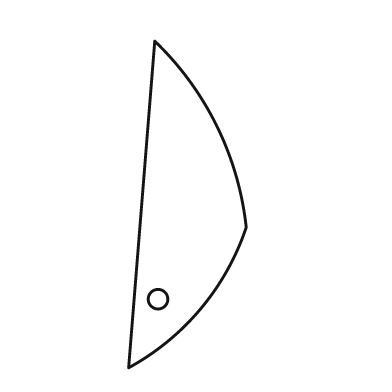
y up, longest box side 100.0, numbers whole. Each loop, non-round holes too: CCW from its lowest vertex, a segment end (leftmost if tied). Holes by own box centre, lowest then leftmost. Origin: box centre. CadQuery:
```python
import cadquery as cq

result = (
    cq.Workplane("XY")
    .moveTo(-18.0, -50.0)
    .threePointArc((4.0, -32.0), (18.0, -7.0))
    .threePointArc((9.0, 24.0), (-10.0, 50.0))
    .close()
    .moveTo(-9.0, -29.0)
    .circle(3.0)
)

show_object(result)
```